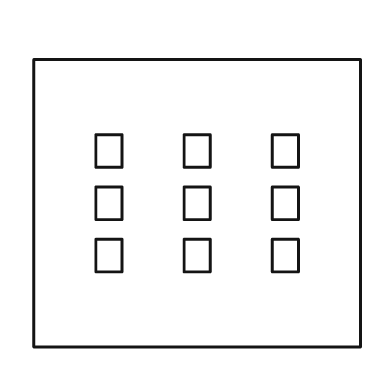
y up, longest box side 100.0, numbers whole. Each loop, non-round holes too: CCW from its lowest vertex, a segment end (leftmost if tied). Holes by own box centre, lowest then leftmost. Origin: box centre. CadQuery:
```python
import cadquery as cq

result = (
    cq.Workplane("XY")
    .moveTo(-50.0, -44.0)
    .lineTo(50.0, -44.0)
    .lineTo(50.0, 44.0)
    .lineTo(-50.0, 44.0)
    .close()
    .moveTo(-31.0, -21.0)
    .lineTo(-23.0, -21.0)
    .lineTo(-23.0, -11.0)
    .lineTo(-31.0, -11.0)
    .close()
    .moveTo(-4.0, -21.0)
    .lineTo(4.0, -21.0)
    .lineTo(4.0, -11.0)
    .lineTo(-4.0, -11.0)
    .close()
    .moveTo(23.0, -21.0)
    .lineTo(31.0, -21.0)
    .lineTo(31.0, -11.0)
    .lineTo(23.0, -11.0)
    .close()
    .moveTo(-31.0, -5.0)
    .lineTo(-23.0, -5.0)
    .lineTo(-23.0, 5.0)
    .lineTo(-31.0, 5.0)
    .close()
    .moveTo(-4.0, -5.0)
    .lineTo(4.0, -5.0)
    .lineTo(4.0, 5.0)
    .lineTo(-4.0, 5.0)
    .close()
    .moveTo(23.0, -5.0)
    .lineTo(31.0, -5.0)
    .lineTo(31.0, 5.0)
    .lineTo(23.0, 5.0)
    .close()
    .moveTo(-31.0, 11.0)
    .lineTo(-23.0, 11.0)
    .lineTo(-23.0, 21.0)
    .lineTo(-31.0, 21.0)
    .close()
    .moveTo(-4.0, 11.0)
    .lineTo(4.0, 11.0)
    .lineTo(4.0, 21.0)
    .lineTo(-4.0, 21.0)
    .close()
    .moveTo(23.0, 11.0)
    .lineTo(31.0, 11.0)
    .lineTo(31.0, 21.0)
    .lineTo(23.0, 21.0)
    .close()
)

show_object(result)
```